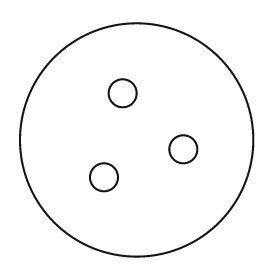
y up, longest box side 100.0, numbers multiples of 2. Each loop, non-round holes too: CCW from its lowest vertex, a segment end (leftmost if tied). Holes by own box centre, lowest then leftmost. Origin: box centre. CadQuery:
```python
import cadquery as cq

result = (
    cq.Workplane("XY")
    .moveTo(0.0, 0.0)
    .circle(50.0)
    .moveTo(-14.0, -16.0)
    .circle(6.0)
    .moveTo(20.0, -4.0)
    .circle(6.0)
    .moveTo(-6.0, 20.0)
    .circle(6.0)
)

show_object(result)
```